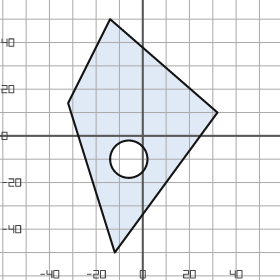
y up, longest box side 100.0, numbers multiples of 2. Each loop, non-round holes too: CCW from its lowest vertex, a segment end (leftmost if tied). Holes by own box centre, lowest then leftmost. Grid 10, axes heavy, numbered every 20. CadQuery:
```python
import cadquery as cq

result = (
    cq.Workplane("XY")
    .moveTo(-12.0, -50.0)
    .lineTo(32.0, 10.0)
    .lineTo(-14.0, 50.0)
    .lineTo(-32.0, 14.0)
    .close()
    .moveTo(-6.0, -10.0)
    .circle(8.0)
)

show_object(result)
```